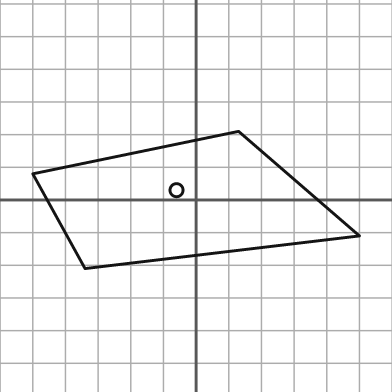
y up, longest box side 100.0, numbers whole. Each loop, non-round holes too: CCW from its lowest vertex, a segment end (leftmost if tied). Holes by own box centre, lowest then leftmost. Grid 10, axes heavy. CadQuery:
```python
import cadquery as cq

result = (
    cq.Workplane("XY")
    .moveTo(-34.0, -21.0)
    .lineTo(50.0, -11.0)
    .lineTo(13.0, 21.0)
    .lineTo(-50.0, 8.0)
    .close()
    .moveTo(-6.0, 3.0)
    .circle(2.0)
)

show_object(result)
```